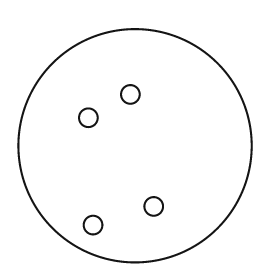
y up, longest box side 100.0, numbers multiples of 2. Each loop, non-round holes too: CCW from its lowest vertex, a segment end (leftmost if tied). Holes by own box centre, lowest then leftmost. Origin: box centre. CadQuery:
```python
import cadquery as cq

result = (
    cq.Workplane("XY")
    .moveTo(0.0, 0.0)
    .circle(50.0)
    .moveTo(-18.0, -34.0)
    .circle(4.0)
    .moveTo(8.0, -26.0)
    .circle(4.0)
    .moveTo(-20.0, 12.0)
    .circle(4.0)
    .moveTo(-2.0, 22.0)
    .circle(4.0)
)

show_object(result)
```